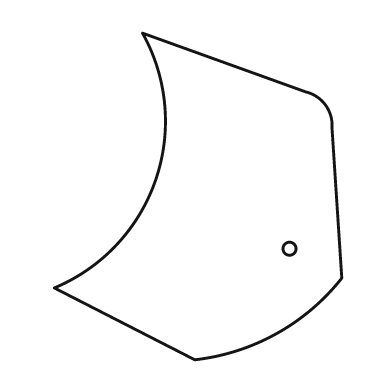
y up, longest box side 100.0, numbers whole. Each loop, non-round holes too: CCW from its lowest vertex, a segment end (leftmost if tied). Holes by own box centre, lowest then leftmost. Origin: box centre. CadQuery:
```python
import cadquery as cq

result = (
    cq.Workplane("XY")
    .moveTo(-1.0, -50.0)
    .threePointArc((24.0, -42.0), (44.0, -25.0))
    .lineTo(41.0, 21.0)
    .threePointArc((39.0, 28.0), (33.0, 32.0))
    .lineTo(-17.0, 50.0)
    .threePointArc((-13.0, 5.0), (-44.0, -28.0))
    .close()
    .moveTo(28.0, -16.0)
    .circle(2.0)
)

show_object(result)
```